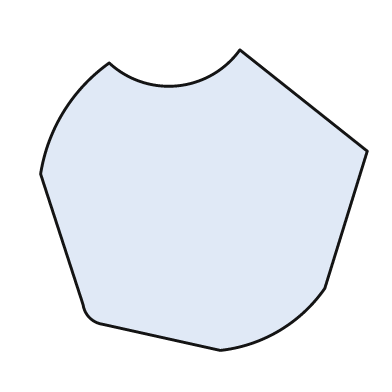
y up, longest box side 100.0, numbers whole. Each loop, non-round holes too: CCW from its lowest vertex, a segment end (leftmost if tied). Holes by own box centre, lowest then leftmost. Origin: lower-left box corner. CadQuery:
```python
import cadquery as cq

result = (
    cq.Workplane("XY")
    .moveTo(55.0, 0.0)
    .threePointArc((73.0, 6.0), (87.0, 19.0))
    .lineTo(100.0, 61.0)
    .lineTo(61.0, 92.0)
    .threePointArc((42.0, 81.0), (21.0, 88.0))
    .threePointArc((7.0, 73.0), (0.0, 54.0))
    .lineTo(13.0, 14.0)
    .threePointArc((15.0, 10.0), (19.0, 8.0))
    .close()
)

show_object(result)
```